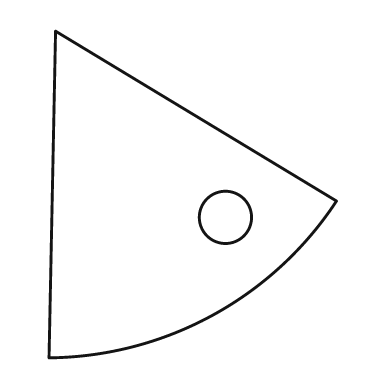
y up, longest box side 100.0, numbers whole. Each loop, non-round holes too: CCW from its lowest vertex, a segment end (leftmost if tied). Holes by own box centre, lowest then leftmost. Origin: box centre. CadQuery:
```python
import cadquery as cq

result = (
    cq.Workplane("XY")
    .moveTo(-44.0, -50.0)
    .threePointArc((6.0, -37.0), (44.0, -2.0))
    .lineTo(-42.0, 50.0)
    .close()
    .moveTo(10.0, -7.0)
    .circle(8.0)
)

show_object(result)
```